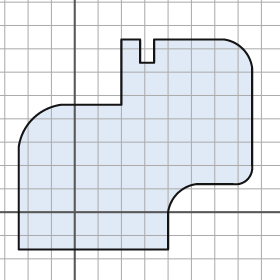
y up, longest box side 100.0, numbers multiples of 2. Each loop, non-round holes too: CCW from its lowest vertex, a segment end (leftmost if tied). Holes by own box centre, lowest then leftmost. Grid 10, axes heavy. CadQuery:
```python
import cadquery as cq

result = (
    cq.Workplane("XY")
    .moveTo(-24.0, -16.0)
    .lineTo(40.0, -16.0)
    .lineTo(40.0, 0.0)
    .threePointArc((44.0, 8.0), (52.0, 12.0))
    .lineTo(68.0, 12.0)
    .threePointArc((74.0, 14.0), (76.0, 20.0))
    .lineTo(76.0, 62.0)
    .threePointArc((72.0, 70.0), (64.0, 74.0))
    .lineTo(34.0, 74.0)
    .lineTo(34.0, 64.0)
    .lineTo(28.0, 64.0)
    .lineTo(28.0, 74.0)
    .lineTo(20.0, 74.0)
    .lineTo(20.0, 46.0)
    .lineTo(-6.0, 46.0)
    .threePointArc((-18.0, 40.0), (-24.0, 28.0))
    .close()
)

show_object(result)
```